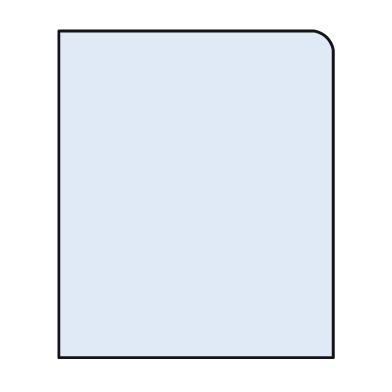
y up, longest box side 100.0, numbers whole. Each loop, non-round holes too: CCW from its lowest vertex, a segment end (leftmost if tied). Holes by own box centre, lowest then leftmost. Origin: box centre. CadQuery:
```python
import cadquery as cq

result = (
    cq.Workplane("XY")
    .moveTo(-42.0, -50.0)
    .lineTo(42.0, -50.0)
    .lineTo(42.0, 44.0)
    .threePointArc((40.0, 48.0), (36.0, 50.0))
    .lineTo(-42.0, 50.0)
    .close()
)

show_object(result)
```